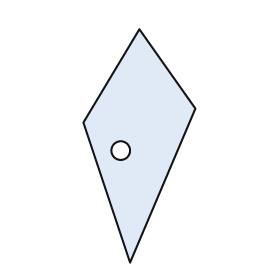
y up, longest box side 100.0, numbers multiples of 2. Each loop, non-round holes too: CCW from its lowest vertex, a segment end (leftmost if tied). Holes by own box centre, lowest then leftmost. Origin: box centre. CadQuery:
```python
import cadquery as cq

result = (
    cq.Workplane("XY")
    .moveTo(-4.0, -50.0)
    .lineTo(24.0, 16.0)
    .lineTo(0.0, 50.0)
    .lineTo(-24.0, 10.0)
    .close()
    .moveTo(-8.0, -2.0)
    .circle(4.0)
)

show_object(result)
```